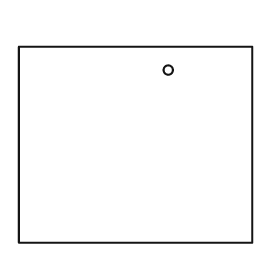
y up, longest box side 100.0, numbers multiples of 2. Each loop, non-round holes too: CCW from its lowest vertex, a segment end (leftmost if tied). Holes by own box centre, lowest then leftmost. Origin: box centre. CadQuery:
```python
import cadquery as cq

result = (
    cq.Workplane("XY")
    .moveTo(-50.0, -42.0)
    .lineTo(50.0, -42.0)
    .lineTo(50.0, 42.0)
    .lineTo(-50.0, 42.0)
    .close()
    .moveTo(14.0, 32.0)
    .circle(2.0)
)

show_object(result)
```